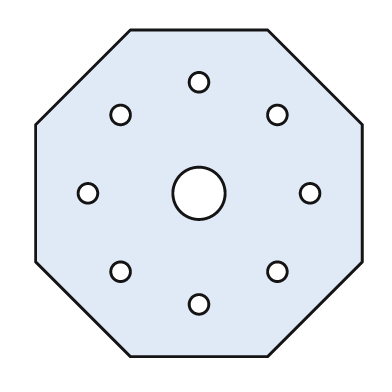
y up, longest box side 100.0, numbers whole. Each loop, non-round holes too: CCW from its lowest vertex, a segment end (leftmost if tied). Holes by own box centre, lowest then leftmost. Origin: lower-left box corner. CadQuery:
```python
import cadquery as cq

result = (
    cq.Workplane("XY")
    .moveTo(29.0, 0.0)
    .lineTo(71.0, 0.0)
    .lineTo(100.0, 29.0)
    .lineTo(100.0, 71.0)
    .lineTo(71.0, 100.0)
    .lineTo(29.0, 100.0)
    .lineTo(0.0, 71.0)
    .lineTo(0.0, 29.0)
    .close()
    .moveTo(50.0, 16.0)
    .circle(3.0)
    .moveTo(26.0, 26.0)
    .circle(3.0)
    .moveTo(74.0, 26.0)
    .circle(3.0)
    .moveTo(16.0, 50.0)
    .circle(3.0)
    .moveTo(50.0, 50.0)
    .circle(8.0)
    .moveTo(84.0, 50.0)
    .circle(3.0)
    .moveTo(26.0, 74.0)
    .circle(3.0)
    .moveTo(74.0, 74.0)
    .circle(3.0)
    .moveTo(50.0, 84.0)
    .circle(3.0)
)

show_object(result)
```